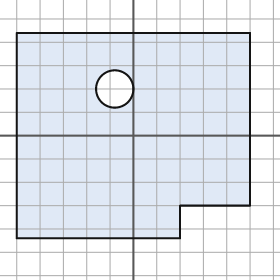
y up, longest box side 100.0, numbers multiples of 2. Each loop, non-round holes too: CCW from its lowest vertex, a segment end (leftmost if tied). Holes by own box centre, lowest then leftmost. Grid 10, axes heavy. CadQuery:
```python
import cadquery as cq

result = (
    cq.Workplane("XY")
    .moveTo(-50.0, -44.0)
    .lineTo(20.0, -44.0)
    .lineTo(20.0, -30.0)
    .lineTo(50.0, -30.0)
    .lineTo(50.0, 44.0)
    .lineTo(-50.0, 44.0)
    .close()
    .moveTo(-8.0, 20.0)
    .circle(8.0)
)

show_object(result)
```